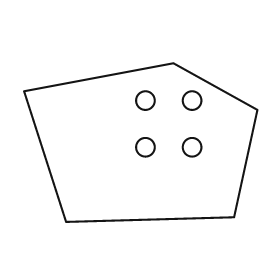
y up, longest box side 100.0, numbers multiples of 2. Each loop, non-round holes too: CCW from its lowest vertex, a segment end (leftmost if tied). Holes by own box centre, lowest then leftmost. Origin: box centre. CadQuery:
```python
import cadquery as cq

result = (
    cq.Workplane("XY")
    .moveTo(-32.0, -34.0)
    .lineTo(40.0, -32.0)
    .lineTo(50.0, 14.0)
    .lineTo(14.0, 34.0)
    .lineTo(-50.0, 22.0)
    .close()
    .moveTo(2.0, -2.0)
    .circle(4.0)
    .moveTo(22.0, -2.0)
    .circle(4.0)
    .moveTo(2.0, 18.0)
    .circle(4.0)
    .moveTo(22.0, 18.0)
    .circle(4.0)
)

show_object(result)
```